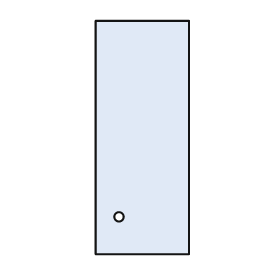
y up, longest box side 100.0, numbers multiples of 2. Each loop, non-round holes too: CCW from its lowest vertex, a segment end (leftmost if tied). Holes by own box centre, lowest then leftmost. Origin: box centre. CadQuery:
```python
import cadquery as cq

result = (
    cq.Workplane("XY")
    .moveTo(-20.0, -50.0)
    .lineTo(20.0, -50.0)
    .lineTo(20.0, 50.0)
    .lineTo(-20.0, 50.0)
    .close()
    .moveTo(-10.0, -34.0)
    .circle(2.0)
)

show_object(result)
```